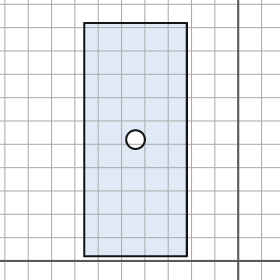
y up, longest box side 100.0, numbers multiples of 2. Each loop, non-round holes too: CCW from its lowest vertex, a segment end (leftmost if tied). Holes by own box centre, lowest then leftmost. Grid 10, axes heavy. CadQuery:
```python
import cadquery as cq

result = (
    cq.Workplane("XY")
    .moveTo(-66.0, 2.0)
    .lineTo(-22.0, 2.0)
    .lineTo(-22.0, 102.0)
    .lineTo(-66.0, 102.0)
    .close()
    .moveTo(-44.0, 52.0)
    .circle(4.0)
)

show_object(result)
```